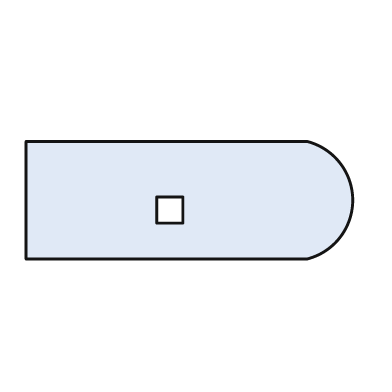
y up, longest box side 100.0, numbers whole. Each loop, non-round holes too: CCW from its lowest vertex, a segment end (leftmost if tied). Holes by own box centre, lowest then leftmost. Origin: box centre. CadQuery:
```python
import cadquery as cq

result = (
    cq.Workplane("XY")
    .moveTo(-50.0, -18.0)
    .lineTo(36.0, -18.0)
    .threePointArc((50.0, 0.0), (36.0, 18.0))
    .lineTo(-50.0, 18.0)
    .close()
    .moveTo(-10.0, -7.0)
    .lineTo(-2.0, -7.0)
    .lineTo(-2.0, 1.0)
    .lineTo(-10.0, 1.0)
    .close()
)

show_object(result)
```